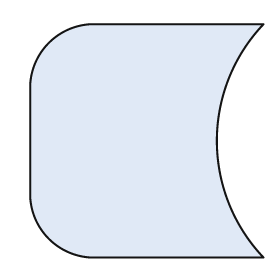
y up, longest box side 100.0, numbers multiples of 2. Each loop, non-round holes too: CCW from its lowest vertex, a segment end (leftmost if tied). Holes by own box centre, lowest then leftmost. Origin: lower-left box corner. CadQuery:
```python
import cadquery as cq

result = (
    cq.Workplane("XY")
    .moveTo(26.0, 0.0)
    .lineTo(100.0, 0.0)
    .threePointArc((80.0, 50.0), (100.0, 100.0))
    .lineTo(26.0, 100.0)
    .threePointArc((8.0, 92.0), (0.0, 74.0))
    .lineTo(0.0, 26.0)
    .threePointArc((8.0, 8.0), (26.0, 0.0))
    .close()
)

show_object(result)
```